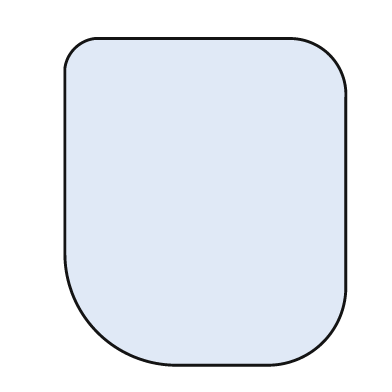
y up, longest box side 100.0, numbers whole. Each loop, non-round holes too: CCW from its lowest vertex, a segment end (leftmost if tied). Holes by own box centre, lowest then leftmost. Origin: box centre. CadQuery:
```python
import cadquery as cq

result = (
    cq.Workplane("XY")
    .moveTo(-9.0, -50.0)
    .lineTo(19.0, -50.0)
    .threePointArc((36.0, -43.0), (43.0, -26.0))
    .lineTo(43.0, 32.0)
    .threePointArc((38.0, 45.0), (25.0, 50.0))
    .lineTo(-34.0, 50.0)
    .threePointArc((-40.0, 47.0), (-43.0, 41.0))
    .lineTo(-43.0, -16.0)
    .threePointArc((-33.0, -40.0), (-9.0, -50.0))
    .close()
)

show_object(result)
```